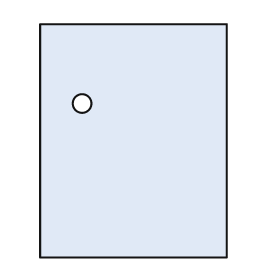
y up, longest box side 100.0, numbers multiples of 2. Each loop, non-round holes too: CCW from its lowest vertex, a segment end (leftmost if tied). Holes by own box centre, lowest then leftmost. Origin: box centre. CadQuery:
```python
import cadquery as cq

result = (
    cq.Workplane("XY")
    .moveTo(-40.0, -50.0)
    .lineTo(40.0, -50.0)
    .lineTo(40.0, 50.0)
    .lineTo(-40.0, 50.0)
    .close()
    .moveTo(-22.0, 16.0)
    .circle(4.0)
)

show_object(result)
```